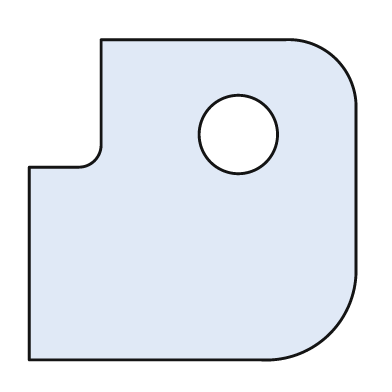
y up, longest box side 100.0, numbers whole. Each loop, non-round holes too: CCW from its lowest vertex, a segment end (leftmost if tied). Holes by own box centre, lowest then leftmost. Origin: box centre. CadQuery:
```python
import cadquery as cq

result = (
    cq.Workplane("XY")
    .moveTo(-50.0, -49.0)
    .lineTo(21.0, -49.0)
    .threePointArc((42.0, -41.0), (50.0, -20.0))
    .lineTo(50.0, 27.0)
    .threePointArc((44.0, 43.0), (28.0, 49.0))
    .lineTo(-28.0, 49.0)
    .lineTo(-28.0, 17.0)
    .threePointArc((-30.0, 12.0), (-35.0, 10.0))
    .lineTo(-50.0, 10.0)
    .close()
    .moveTo(14.0, 20.0)
    .circle(12.0)
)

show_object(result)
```